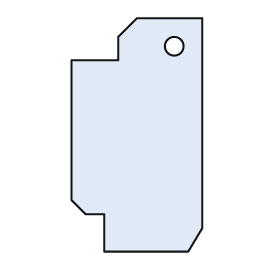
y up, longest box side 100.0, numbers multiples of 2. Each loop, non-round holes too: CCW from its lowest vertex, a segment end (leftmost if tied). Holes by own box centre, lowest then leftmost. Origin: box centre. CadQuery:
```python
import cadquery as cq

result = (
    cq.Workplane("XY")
    .moveTo(-14.0, -50.0)
    .lineTo(22.0, -50.0)
    .lineTo(28.0, -40.0)
    .lineTo(28.0, 50.0)
    .lineTo(0.0, 50.0)
    .lineTo(-8.0, 42.0)
    .lineTo(-8.0, 32.0)
    .lineTo(-28.0, 32.0)
    .lineTo(-28.0, -28.0)
    .lineTo(-22.0, -34.0)
    .lineTo(-14.0, -34.0)
    .close()
    .moveTo(16.0, 38.0)
    .circle(4.0)
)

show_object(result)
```